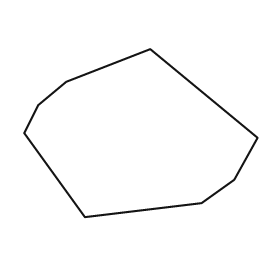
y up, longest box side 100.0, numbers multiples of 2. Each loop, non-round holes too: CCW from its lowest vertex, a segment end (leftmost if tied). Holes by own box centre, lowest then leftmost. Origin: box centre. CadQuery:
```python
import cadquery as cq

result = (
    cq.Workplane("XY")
    .moveTo(-24.0, -36.0)
    .lineTo(26.0, -30.0)
    .lineTo(40.0, -20.0)
    .lineTo(50.0, -2.0)
    .lineTo(4.0, 36.0)
    .lineTo(-32.0, 22.0)
    .lineTo(-44.0, 12.0)
    .lineTo(-50.0, 0.0)
    .close()
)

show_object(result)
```